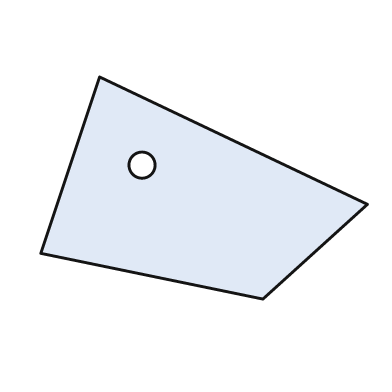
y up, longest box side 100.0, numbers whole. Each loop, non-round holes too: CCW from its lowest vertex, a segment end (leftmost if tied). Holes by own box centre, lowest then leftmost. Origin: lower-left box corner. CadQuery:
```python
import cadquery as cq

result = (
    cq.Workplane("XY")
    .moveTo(68.0, 0.0)
    .lineTo(100.0, 29.0)
    .lineTo(18.0, 68.0)
    .lineTo(0.0, 14.0)
    .close()
    .moveTo(31.0, 41.0)
    .circle(4.0)
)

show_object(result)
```